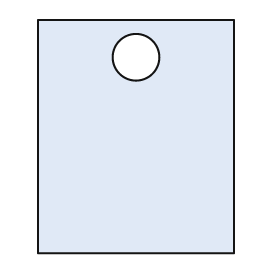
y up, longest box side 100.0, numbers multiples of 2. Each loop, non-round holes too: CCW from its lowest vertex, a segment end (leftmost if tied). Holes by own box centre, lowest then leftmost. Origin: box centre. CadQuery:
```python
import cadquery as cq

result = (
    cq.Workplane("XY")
    .moveTo(-42.0, -50.0)
    .lineTo(42.0, -50.0)
    .lineTo(42.0, 50.0)
    .lineTo(-42.0, 50.0)
    .close()
    .moveTo(0.0, 34.0)
    .circle(10.0)
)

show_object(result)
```